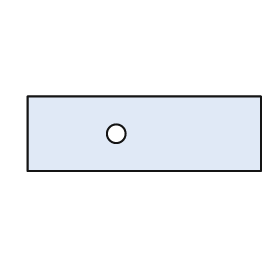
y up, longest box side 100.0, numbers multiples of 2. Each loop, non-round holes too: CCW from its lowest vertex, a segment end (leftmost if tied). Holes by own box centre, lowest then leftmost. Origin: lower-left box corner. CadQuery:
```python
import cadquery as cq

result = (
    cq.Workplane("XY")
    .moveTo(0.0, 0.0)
    .lineTo(100.0, 0.0)
    .lineTo(100.0, 32.0)
    .lineTo(0.0, 32.0)
    .close()
    .moveTo(38.0, 16.0)
    .circle(4.0)
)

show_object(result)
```